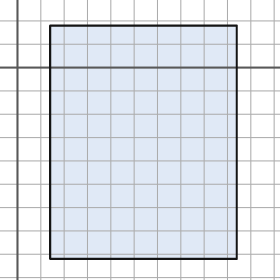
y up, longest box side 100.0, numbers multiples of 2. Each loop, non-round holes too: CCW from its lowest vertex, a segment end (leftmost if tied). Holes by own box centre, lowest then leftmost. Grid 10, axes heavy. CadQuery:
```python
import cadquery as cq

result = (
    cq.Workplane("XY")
    .moveTo(14.0, -82.0)
    .lineTo(94.0, -82.0)
    .lineTo(94.0, 18.0)
    .lineTo(14.0, 18.0)
    .close()
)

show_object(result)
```